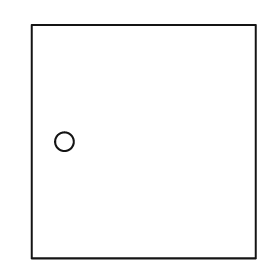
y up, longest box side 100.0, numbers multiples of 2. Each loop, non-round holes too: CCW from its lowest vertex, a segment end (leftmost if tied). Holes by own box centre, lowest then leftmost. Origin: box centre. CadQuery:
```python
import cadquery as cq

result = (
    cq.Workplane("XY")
    .moveTo(-48.0, -50.0)
    .lineTo(48.0, -50.0)
    .lineTo(48.0, 50.0)
    .lineTo(-48.0, 50.0)
    .close()
    .moveTo(-34.0, 0.0)
    .circle(4.0)
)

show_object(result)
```